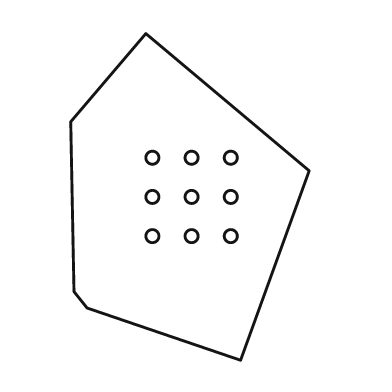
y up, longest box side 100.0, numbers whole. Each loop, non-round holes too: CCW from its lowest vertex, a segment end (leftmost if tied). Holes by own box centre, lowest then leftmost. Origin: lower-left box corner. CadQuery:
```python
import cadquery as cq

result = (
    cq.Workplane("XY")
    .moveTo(52.0, 0.0)
    .lineTo(73.0, 58.0)
    .lineTo(23.0, 100.0)
    .lineTo(0.0, 73.0)
    .lineTo(1.0, 21.0)
    .lineTo(5.0, 16.0)
    .close()
    .moveTo(25.0, 38.0)
    .circle(2.0)
    .moveTo(37.0, 38.0)
    .circle(2.0)
    .moveTo(49.0, 38.0)
    .circle(2.0)
    .moveTo(25.0, 50.0)
    .circle(2.0)
    .moveTo(37.0, 50.0)
    .circle(2.0)
    .moveTo(49.0, 50.0)
    .circle(2.0)
    .moveTo(25.0, 62.0)
    .circle(2.0)
    .moveTo(37.0, 62.0)
    .circle(2.0)
    .moveTo(49.0, 62.0)
    .circle(2.0)
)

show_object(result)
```